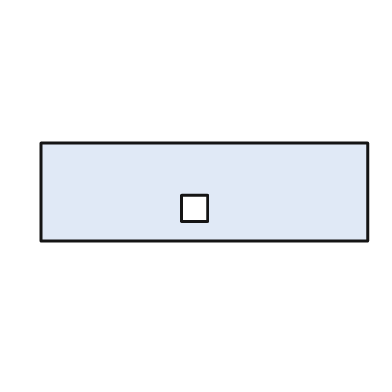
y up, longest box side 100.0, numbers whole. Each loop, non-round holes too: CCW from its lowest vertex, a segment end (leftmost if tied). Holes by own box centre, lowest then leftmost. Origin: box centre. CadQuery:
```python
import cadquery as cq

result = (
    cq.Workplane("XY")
    .moveTo(-50.0, -15.0)
    .lineTo(50.0, -15.0)
    .lineTo(50.0, 15.0)
    .lineTo(-50.0, 15.0)
    .close()
    .moveTo(-7.0, -9.0)
    .lineTo(1.0, -9.0)
    .lineTo(1.0, -1.0)
    .lineTo(-7.0, -1.0)
    .close()
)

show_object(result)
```